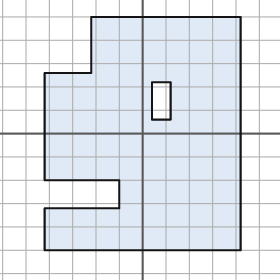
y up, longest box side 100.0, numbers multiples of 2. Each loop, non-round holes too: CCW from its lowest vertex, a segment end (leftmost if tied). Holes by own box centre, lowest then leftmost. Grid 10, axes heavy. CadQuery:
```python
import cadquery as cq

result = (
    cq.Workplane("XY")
    .moveTo(-42.0, -50.0)
    .lineTo(42.0, -50.0)
    .lineTo(42.0, 50.0)
    .lineTo(-22.0, 50.0)
    .lineTo(-22.0, 26.0)
    .lineTo(-42.0, 26.0)
    .lineTo(-42.0, -20.0)
    .lineTo(-10.0, -20.0)
    .lineTo(-10.0, -32.0)
    .lineTo(-42.0, -32.0)
    .close()
    .moveTo(4.0, 6.0)
    .lineTo(12.0, 6.0)
    .lineTo(12.0, 22.0)
    .lineTo(4.0, 22.0)
    .close()
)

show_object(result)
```